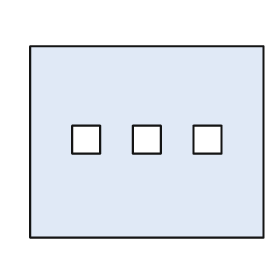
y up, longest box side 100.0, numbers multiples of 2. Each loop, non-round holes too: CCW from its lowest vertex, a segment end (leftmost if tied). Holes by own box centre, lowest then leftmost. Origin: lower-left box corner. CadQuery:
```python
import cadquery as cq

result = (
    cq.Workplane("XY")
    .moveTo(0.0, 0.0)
    .lineTo(100.0, 0.0)
    .lineTo(100.0, 82.0)
    .lineTo(0.0, 82.0)
    .close()
    .moveTo(18.0, 36.0)
    .lineTo(30.0, 36.0)
    .lineTo(30.0, 48.0)
    .lineTo(18.0, 48.0)
    .close()
    .moveTo(44.0, 36.0)
    .lineTo(56.0, 36.0)
    .lineTo(56.0, 48.0)
    .lineTo(44.0, 48.0)
    .close()
    .moveTo(70.0, 36.0)
    .lineTo(82.0, 36.0)
    .lineTo(82.0, 48.0)
    .lineTo(70.0, 48.0)
    .close()
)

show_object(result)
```